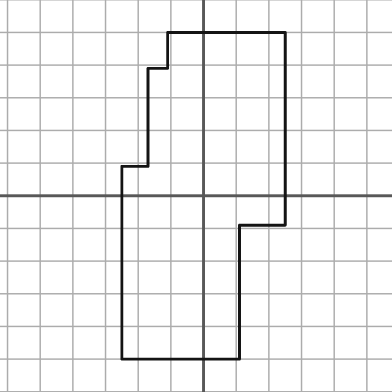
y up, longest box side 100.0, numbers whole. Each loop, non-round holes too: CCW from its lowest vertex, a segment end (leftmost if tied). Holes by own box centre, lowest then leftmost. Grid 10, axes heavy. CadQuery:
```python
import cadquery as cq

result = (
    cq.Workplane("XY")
    .moveTo(-25.0, -50.0)
    .lineTo(11.0, -50.0)
    .lineTo(11.0, -9.0)
    .lineTo(25.0, -9.0)
    .lineTo(25.0, 50.0)
    .lineTo(-11.0, 50.0)
    .lineTo(-11.0, 39.0)
    .lineTo(-17.0, 39.0)
    .lineTo(-17.0, 9.0)
    .lineTo(-25.0, 9.0)
    .close()
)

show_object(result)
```